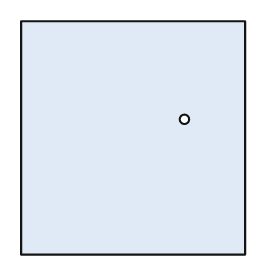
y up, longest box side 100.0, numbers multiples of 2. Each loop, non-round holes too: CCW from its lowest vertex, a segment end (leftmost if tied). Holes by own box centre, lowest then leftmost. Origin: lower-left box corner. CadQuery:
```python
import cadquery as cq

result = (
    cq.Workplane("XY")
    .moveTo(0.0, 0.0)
    .lineTo(96.0, 0.0)
    .lineTo(96.0, 100.0)
    .lineTo(0.0, 100.0)
    .close()
    .moveTo(70.0, 58.0)
    .circle(2.0)
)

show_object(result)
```